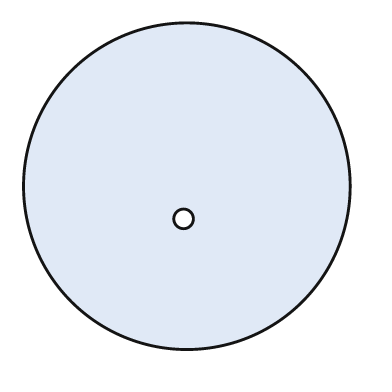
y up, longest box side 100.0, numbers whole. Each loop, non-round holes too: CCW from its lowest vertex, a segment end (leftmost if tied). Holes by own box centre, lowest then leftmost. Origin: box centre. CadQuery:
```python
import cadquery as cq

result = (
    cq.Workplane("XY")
    .moveTo(0.0, 0.0)
    .circle(50.0)
    .moveTo(-1.0, -10.0)
    .circle(3.0)
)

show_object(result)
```